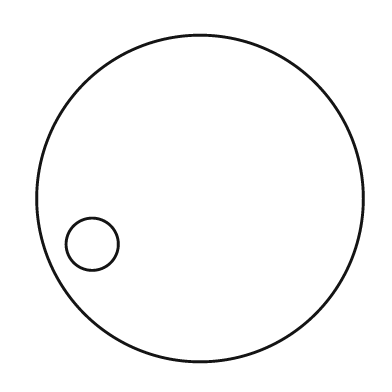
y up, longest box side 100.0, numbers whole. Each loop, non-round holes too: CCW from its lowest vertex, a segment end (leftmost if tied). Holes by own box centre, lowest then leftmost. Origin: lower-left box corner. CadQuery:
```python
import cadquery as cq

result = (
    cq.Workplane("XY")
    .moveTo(50.0, 50.0)
    .circle(50.0)
    .moveTo(17.0, 36.0)
    .circle(8.0)
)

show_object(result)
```